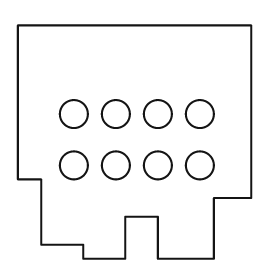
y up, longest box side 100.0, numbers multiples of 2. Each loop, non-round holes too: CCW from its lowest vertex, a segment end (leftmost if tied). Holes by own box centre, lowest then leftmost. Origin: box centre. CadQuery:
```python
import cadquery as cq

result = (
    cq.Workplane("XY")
    .moveTo(-22.0, -50.0)
    .lineTo(-4.0, -50.0)
    .lineTo(-4.0, -32.0)
    .lineTo(10.0, -32.0)
    .lineTo(10.0, -50.0)
    .lineTo(34.0, -50.0)
    .lineTo(34.0, -24.0)
    .lineTo(50.0, -24.0)
    .lineTo(50.0, 50.0)
    .lineTo(-50.0, 50.0)
    .lineTo(-50.0, -16.0)
    .lineTo(-40.0, -16.0)
    .lineTo(-40.0, -44.0)
    .lineTo(-22.0, -44.0)
    .close()
    .moveTo(-26.0, -10.0)
    .circle(6.0)
    .moveTo(-8.0, -10.0)
    .circle(6.0)
    .moveTo(10.0, -10.0)
    .circle(6.0)
    .moveTo(28.0, -10.0)
    .circle(6.0)
    .moveTo(-26.0, 12.0)
    .circle(6.0)
    .moveTo(-8.0, 12.0)
    .circle(6.0)
    .moveTo(10.0, 12.0)
    .circle(6.0)
    .moveTo(28.0, 12.0)
    .circle(6.0)
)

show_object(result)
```